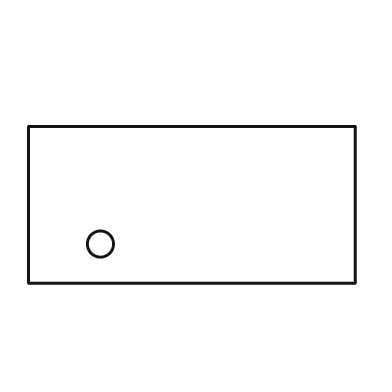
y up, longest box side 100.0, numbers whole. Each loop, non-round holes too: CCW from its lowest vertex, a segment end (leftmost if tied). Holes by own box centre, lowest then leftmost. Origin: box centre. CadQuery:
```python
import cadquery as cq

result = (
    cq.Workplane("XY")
    .moveTo(-50.0, -24.0)
    .lineTo(50.0, -24.0)
    .lineTo(50.0, 24.0)
    .lineTo(-50.0, 24.0)
    .close()
    .moveTo(-28.0, -12.0)
    .circle(4.0)
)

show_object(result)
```